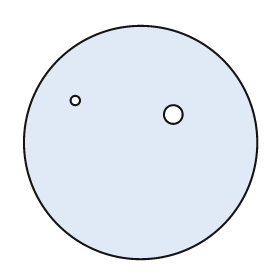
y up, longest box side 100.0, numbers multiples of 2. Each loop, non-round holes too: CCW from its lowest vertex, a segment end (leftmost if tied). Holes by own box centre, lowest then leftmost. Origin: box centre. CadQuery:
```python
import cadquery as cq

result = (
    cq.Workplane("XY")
    .moveTo(0.0, 0.0)
    .circle(50.0)
    .moveTo(14.0, 12.0)
    .circle(4.0)
    .moveTo(-28.0, 18.0)
    .circle(2.0)
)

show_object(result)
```